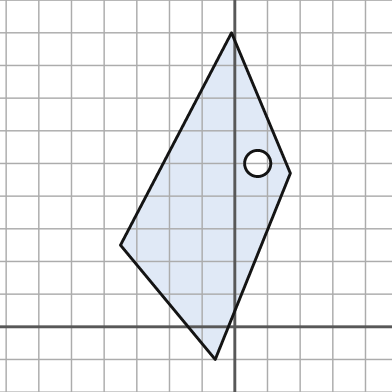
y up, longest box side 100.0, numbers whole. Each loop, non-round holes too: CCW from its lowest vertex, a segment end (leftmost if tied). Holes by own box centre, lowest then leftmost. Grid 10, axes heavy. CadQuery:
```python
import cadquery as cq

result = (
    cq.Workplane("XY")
    .moveTo(-6.0, -10.0)
    .lineTo(17.0, 47.0)
    .lineTo(-1.0, 90.0)
    .lineTo(-35.0, 25.0)
    .close()
    .moveTo(7.0, 50.0)
    .circle(4.0)
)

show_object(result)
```